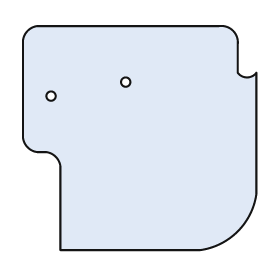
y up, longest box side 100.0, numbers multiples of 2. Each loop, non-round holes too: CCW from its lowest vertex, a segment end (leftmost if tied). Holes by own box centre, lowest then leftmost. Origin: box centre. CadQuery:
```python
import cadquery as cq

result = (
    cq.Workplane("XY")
    .moveTo(-34.0, -48.0)
    .lineTo(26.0, -48.0)
    .threePointArc((42.0, -40.0), (50.0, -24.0))
    .lineTo(50.0, 28.0)
    .threePointArc((46.0, 26.0), (42.0, 28.0))
    .lineTo(42.0, 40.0)
    .threePointArc((40.0, 46.0), (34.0, 48.0))
    .lineTo(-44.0, 48.0)
    .threePointArc((-48.0, 46.0), (-50.0, 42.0))
    .lineTo(-50.0, 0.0)
    .threePointArc((-48.0, -4.0), (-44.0, -6.0))
    .lineTo(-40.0, -6.0)
    .threePointArc((-36.0, -8.0), (-34.0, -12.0))
    .close()
    .moveTo(-38.0, 18.0)
    .circle(2.0)
    .moveTo(-6.0, 24.0)
    .circle(2.0)
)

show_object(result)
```